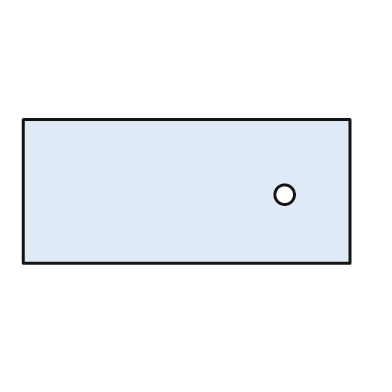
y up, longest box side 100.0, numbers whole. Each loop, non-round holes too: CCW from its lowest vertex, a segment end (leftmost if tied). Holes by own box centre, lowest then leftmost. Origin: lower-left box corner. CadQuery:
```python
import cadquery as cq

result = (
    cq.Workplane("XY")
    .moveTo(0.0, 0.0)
    .lineTo(100.0, 0.0)
    .lineTo(100.0, 44.0)
    .lineTo(0.0, 44.0)
    .close()
    .moveTo(80.0, 21.0)
    .circle(3.0)
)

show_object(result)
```